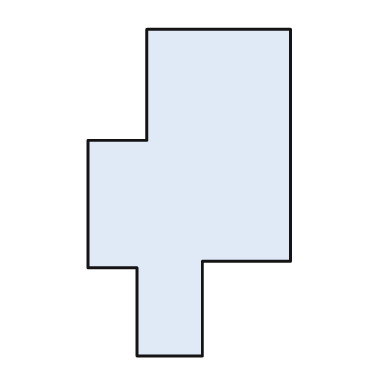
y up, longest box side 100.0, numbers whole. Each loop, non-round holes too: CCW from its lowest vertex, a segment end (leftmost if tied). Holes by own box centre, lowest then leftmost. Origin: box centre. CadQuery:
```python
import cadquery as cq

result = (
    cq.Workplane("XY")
    .moveTo(-16.0, -50.0)
    .lineTo(4.0, -50.0)
    .lineTo(4.0, -21.0)
    .lineTo(31.0, -21.0)
    .lineTo(31.0, 50.0)
    .lineTo(-13.0, 50.0)
    .lineTo(-13.0, 16.0)
    .lineTo(-31.0, 16.0)
    .lineTo(-31.0, -23.0)
    .lineTo(-16.0, -23.0)
    .close()
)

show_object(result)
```